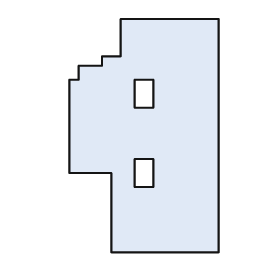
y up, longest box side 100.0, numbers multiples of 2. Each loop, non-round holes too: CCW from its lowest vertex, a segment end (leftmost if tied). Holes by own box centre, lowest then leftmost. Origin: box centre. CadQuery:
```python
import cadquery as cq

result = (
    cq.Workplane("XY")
    .moveTo(-14.0, -50.0)
    .lineTo(32.0, -50.0)
    .lineTo(32.0, 50.0)
    .lineTo(-10.0, 50.0)
    .lineTo(-10.0, 34.0)
    .lineTo(-18.0, 34.0)
    .lineTo(-18.0, 30.0)
    .lineTo(-28.0, 30.0)
    .lineTo(-28.0, 24.0)
    .lineTo(-32.0, 24.0)
    .lineTo(-32.0, -16.0)
    .lineTo(-14.0, -16.0)
    .close()
    .moveTo(-4.0, -22.0)
    .lineTo(4.0, -22.0)
    .lineTo(4.0, -10.0)
    .lineTo(-4.0, -10.0)
    .close()
    .moveTo(-4.0, 12.0)
    .lineTo(4.0, 12.0)
    .lineTo(4.0, 24.0)
    .lineTo(-4.0, 24.0)
    .close()
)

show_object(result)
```